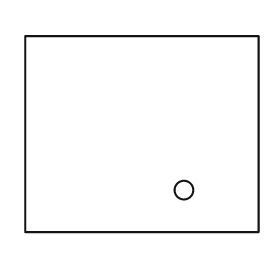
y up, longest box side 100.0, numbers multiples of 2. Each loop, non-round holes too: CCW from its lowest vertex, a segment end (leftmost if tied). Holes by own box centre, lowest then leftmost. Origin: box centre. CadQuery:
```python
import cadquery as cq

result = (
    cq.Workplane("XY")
    .moveTo(-50.0, -42.0)
    .lineTo(50.0, -42.0)
    .lineTo(50.0, 42.0)
    .lineTo(-50.0, 42.0)
    .close()
    .moveTo(18.0, -24.0)
    .circle(4.0)
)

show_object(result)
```